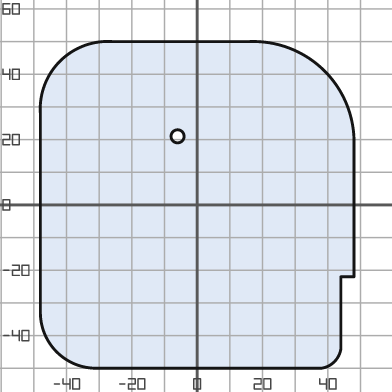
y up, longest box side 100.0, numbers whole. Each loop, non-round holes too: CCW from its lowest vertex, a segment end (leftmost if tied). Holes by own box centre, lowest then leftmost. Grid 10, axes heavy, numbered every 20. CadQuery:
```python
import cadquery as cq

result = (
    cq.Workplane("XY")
    .moveTo(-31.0, -50.0)
    .lineTo(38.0, -50.0)
    .threePointArc((42.0, -48.0), (44.0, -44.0))
    .lineTo(44.0, -22.0)
    .lineTo(48.0, -22.0)
    .lineTo(48.0, 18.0)
    .threePointArc((39.0, 41.0), (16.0, 50.0))
    .lineTo(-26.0, 50.0)
    .threePointArc((-42.0, 44.0), (-48.0, 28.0))
    .lineTo(-48.0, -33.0)
    .threePointArc((-43.0, -45.0), (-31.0, -50.0))
    .close()
    .moveTo(-6.0, 21.0)
    .circle(2.0)
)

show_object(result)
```